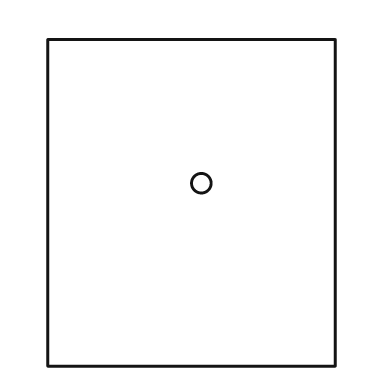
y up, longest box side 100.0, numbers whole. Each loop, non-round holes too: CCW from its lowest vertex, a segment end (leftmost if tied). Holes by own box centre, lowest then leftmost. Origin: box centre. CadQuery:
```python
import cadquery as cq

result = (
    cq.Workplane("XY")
    .moveTo(-44.0, -50.0)
    .lineTo(44.0, -50.0)
    .lineTo(44.0, 50.0)
    .lineTo(-44.0, 50.0)
    .close()
    .moveTo(3.0, 6.0)
    .circle(3.0)
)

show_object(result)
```